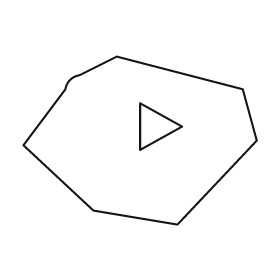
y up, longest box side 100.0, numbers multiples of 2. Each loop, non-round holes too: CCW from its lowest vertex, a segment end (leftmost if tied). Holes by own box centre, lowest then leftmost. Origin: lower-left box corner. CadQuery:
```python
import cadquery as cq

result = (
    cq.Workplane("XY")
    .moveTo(66.0, 0.0)
    .lineTo(100.0, 36.0)
    .lineTo(94.0, 58.0)
    .lineTo(40.0, 72.0)
    .lineTo(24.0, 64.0)
    .threePointArc((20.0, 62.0), (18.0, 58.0))
    .lineTo(0.0, 34.0)
    .lineTo(30.0, 6.0)
    .close()
    .moveTo(50.0, 32.0)
    .lineTo(68.0, 42.0)
    .lineTo(50.0, 52.0)
    .close()
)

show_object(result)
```